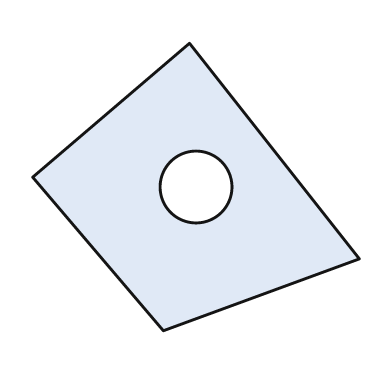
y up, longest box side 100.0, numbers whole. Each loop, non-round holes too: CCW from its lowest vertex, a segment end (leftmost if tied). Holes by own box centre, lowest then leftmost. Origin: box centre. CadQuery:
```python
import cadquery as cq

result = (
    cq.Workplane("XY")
    .moveTo(-10.0, -44.0)
    .lineTo(50.0, -22.0)
    .lineTo(-2.0, 44.0)
    .lineTo(-50.0, 3.0)
    .close()
    .moveTo(0.0, 0.0)
    .circle(11.0)
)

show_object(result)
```